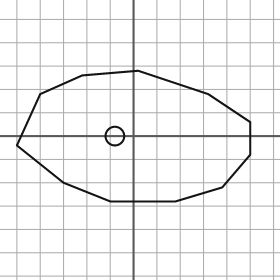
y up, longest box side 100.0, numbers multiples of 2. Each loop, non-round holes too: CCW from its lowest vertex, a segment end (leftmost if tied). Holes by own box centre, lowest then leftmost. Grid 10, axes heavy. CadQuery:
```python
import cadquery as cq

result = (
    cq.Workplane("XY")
    .moveTo(-10.0, -28.0)
    .lineTo(18.0, -28.0)
    .lineTo(38.0, -22.0)
    .lineTo(50.0, -8.0)
    .lineTo(50.0, 6.0)
    .lineTo(32.0, 18.0)
    .lineTo(2.0, 28.0)
    .lineTo(-22.0, 26.0)
    .lineTo(-40.0, 18.0)
    .lineTo(-50.0, -4.0)
    .lineTo(-30.0, -20.0)
    .close()
    .moveTo(-8.0, 0.0)
    .circle(4.0)
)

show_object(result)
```